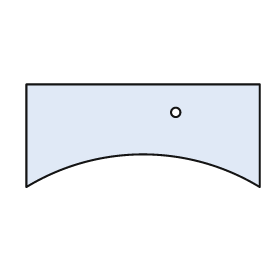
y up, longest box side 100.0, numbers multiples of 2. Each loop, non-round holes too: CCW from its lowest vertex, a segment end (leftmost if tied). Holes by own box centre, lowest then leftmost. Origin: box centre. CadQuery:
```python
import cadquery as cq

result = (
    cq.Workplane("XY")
    .moveTo(-50.0, -22.0)
    .threePointArc((0.0, -8.0), (50.0, -22.0))
    .lineTo(50.0, 22.0)
    .lineTo(-50.0, 22.0)
    .close()
    .moveTo(14.0, 10.0)
    .circle(2.0)
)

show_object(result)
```